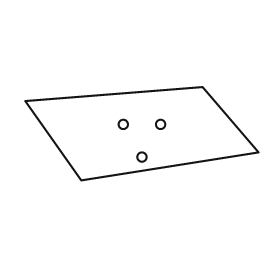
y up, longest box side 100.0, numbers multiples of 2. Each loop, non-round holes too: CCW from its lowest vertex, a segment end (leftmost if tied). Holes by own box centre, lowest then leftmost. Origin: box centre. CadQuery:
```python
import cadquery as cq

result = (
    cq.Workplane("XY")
    .moveTo(-26.0, -20.0)
    .lineTo(50.0, -8.0)
    .lineTo(26.0, 20.0)
    .lineTo(-50.0, 14.0)
    .close()
    .moveTo(0.0, -10.0)
    .circle(2.0)
    .moveTo(-8.0, 4.0)
    .circle(2.0)
    .moveTo(8.0, 4.0)
    .circle(2.0)
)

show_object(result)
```